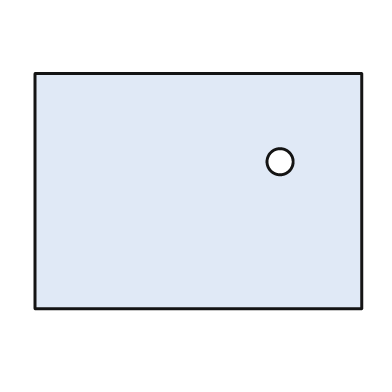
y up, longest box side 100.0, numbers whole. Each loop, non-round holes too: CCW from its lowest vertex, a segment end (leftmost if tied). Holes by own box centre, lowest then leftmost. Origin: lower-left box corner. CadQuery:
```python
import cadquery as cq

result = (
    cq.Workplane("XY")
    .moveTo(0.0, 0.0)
    .lineTo(100.0, 0.0)
    .lineTo(100.0, 72.0)
    .lineTo(0.0, 72.0)
    .close()
    .moveTo(75.0, 45.0)
    .circle(4.0)
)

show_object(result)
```